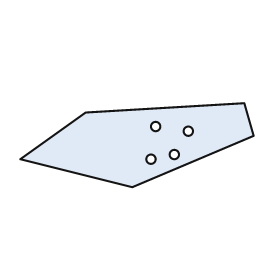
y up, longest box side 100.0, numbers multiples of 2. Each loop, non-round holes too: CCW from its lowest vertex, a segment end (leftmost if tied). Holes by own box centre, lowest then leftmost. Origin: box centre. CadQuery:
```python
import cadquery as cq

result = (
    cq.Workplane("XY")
    .moveTo(-2.0, -18.0)
    .lineTo(50.0, 4.0)
    .lineTo(46.0, 18.0)
    .lineTo(-22.0, 14.0)
    .lineTo(-50.0, -6.0)
    .close()
    .moveTo(6.0, -6.0)
    .circle(2.0)
    .moveTo(16.0, -4.0)
    .circle(2.0)
    .moveTo(22.0, 6.0)
    .circle(2.0)
    .moveTo(8.0, 8.0)
    .circle(2.0)
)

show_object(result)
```